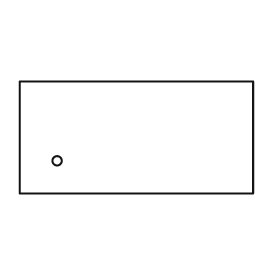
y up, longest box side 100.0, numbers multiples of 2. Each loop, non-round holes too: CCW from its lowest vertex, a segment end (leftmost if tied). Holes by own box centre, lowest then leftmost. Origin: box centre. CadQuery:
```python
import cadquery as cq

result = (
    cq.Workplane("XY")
    .moveTo(-50.0, -24.0)
    .lineTo(50.0, -24.0)
    .lineTo(50.0, 24.0)
    .lineTo(-50.0, 24.0)
    .close()
    .moveTo(-34.0, -10.0)
    .circle(2.0)
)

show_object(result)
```